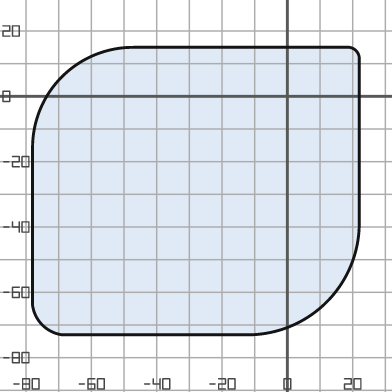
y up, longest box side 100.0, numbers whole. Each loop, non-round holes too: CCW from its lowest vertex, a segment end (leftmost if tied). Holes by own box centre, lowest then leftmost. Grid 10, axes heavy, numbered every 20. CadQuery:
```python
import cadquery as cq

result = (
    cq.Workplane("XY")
    .moveTo(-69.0, -73.0)
    .lineTo(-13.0, -73.0)
    .threePointArc((12.0, -63.0), (22.0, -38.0))
    .lineTo(22.0, 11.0)
    .threePointArc((21.0, 14.0), (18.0, 15.0))
    .lineTo(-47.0, 15.0)
    .threePointArc((-69.0, 6.0), (-78.0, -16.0))
    .lineTo(-78.0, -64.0)
    .threePointArc((-75.0, -70.0), (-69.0, -73.0))
    .close()
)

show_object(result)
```